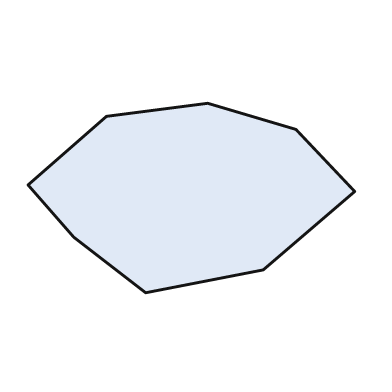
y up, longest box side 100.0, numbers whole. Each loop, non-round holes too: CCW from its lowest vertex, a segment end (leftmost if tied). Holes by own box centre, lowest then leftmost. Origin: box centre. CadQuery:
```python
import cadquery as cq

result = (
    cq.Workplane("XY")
    .moveTo(-14.0, -29.0)
    .lineTo(22.0, -22.0)
    .lineTo(50.0, 2.0)
    .lineTo(32.0, 21.0)
    .lineTo(5.0, 29.0)
    .lineTo(-26.0, 25.0)
    .lineTo(-50.0, 4.0)
    .lineTo(-36.0, -12.0)
    .close()
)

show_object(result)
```